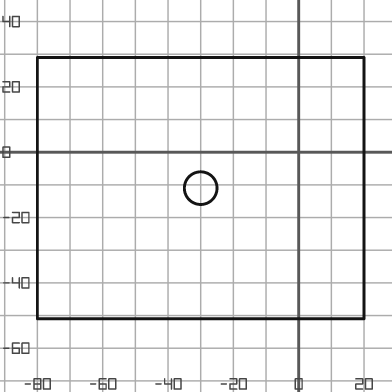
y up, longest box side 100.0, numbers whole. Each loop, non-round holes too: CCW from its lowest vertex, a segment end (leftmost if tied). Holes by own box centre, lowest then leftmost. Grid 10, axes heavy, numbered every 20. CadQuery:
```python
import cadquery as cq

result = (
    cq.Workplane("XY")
    .moveTo(-80.0, -51.0)
    .lineTo(20.0, -51.0)
    .lineTo(20.0, 29.0)
    .lineTo(-80.0, 29.0)
    .close()
    .moveTo(-30.0, -11.0)
    .circle(5.0)
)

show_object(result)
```